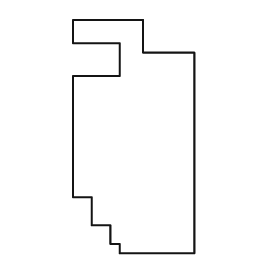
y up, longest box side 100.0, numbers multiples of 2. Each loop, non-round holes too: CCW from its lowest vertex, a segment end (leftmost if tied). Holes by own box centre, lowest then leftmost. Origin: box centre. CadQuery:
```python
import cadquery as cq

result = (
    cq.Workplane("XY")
    .moveTo(-6.0, -50.0)
    .lineTo(26.0, -50.0)
    .lineTo(26.0, 36.0)
    .lineTo(4.0, 36.0)
    .lineTo(4.0, 50.0)
    .lineTo(-26.0, 50.0)
    .lineTo(-26.0, 40.0)
    .lineTo(-6.0, 40.0)
    .lineTo(-6.0, 26.0)
    .lineTo(-26.0, 26.0)
    .lineTo(-26.0, -26.0)
    .lineTo(-18.0, -26.0)
    .lineTo(-18.0, -38.0)
    .lineTo(-10.0, -38.0)
    .lineTo(-10.0, -46.0)
    .lineTo(-6.0, -46.0)
    .close()
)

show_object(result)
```